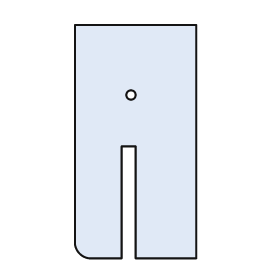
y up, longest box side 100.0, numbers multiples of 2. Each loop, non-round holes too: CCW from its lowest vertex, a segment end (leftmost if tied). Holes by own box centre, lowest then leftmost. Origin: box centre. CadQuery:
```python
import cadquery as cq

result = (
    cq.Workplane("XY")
    .moveTo(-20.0, -50.0)
    .lineTo(-6.0, -50.0)
    .lineTo(-6.0, -2.0)
    .lineTo(0.0, -2.0)
    .lineTo(0.0, -50.0)
    .lineTo(26.0, -50.0)
    .lineTo(26.0, 50.0)
    .lineTo(-26.0, 50.0)
    .lineTo(-26.0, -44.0)
    .threePointArc((-24.0, -48.0), (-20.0, -50.0))
    .close()
    .moveTo(-2.0, 20.0)
    .circle(2.0)
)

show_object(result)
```